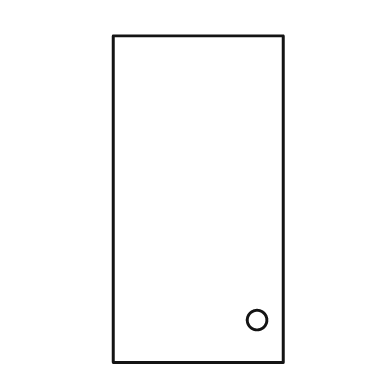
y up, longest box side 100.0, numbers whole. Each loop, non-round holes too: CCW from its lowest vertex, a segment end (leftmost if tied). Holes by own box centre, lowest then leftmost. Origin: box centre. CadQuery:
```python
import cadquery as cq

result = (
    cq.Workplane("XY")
    .moveTo(-26.0, -50.0)
    .lineTo(26.0, -50.0)
    .lineTo(26.0, 50.0)
    .lineTo(-26.0, 50.0)
    .close()
    .moveTo(18.0, -37.0)
    .circle(3.0)
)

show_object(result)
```